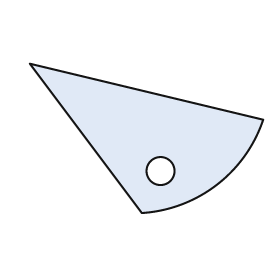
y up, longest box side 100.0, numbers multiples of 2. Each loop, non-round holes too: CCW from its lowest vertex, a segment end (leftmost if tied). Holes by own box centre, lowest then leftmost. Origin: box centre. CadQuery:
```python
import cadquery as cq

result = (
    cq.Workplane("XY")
    .moveTo(-2.0, -32.0)
    .threePointArc((30.0, -20.0), (50.0, 8.0))
    .lineTo(-50.0, 32.0)
    .close()
    .moveTo(6.0, -14.0)
    .circle(6.0)
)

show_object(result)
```